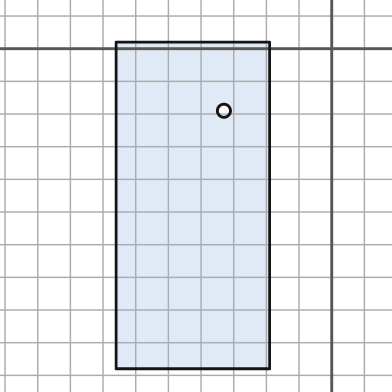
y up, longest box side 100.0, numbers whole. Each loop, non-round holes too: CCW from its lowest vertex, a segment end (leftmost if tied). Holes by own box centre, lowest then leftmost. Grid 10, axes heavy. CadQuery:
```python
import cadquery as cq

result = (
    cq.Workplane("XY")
    .moveTo(-66.0, -98.0)
    .lineTo(-19.0, -98.0)
    .lineTo(-19.0, 2.0)
    .lineTo(-66.0, 2.0)
    .close()
    .moveTo(-33.0, -19.0)
    .circle(2.0)
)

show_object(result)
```